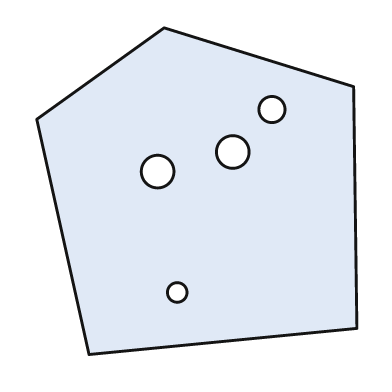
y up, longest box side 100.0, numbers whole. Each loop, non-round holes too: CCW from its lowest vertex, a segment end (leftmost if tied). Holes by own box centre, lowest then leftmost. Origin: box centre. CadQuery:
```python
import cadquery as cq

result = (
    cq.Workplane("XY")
    .moveTo(-33.0, -50.0)
    .lineTo(49.0, -42.0)
    .lineTo(48.0, 32.0)
    .lineTo(-10.0, 50.0)
    .lineTo(-49.0, 22.0)
    .close()
    .moveTo(-6.0, -31.0)
    .circle(3.0)
    .moveTo(-12.0, 6.0)
    .circle(5.0)
    .moveTo(11.0, 12.0)
    .circle(5.0)
    .moveTo(23.0, 25.0)
    .circle(4.0)
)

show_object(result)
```